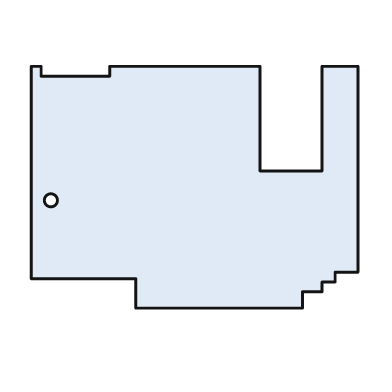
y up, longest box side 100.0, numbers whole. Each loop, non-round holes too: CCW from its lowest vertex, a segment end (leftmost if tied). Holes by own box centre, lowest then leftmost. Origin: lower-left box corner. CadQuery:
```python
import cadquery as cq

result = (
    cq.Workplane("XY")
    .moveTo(32.0, 0.0)
    .lineTo(83.0, 0.0)
    .lineTo(83.0, 5.0)
    .lineTo(89.0, 5.0)
    .lineTo(89.0, 8.0)
    .lineTo(93.0, 8.0)
    .lineTo(93.0, 11.0)
    .lineTo(100.0, 11.0)
    .lineTo(100.0, 74.0)
    .lineTo(89.0, 74.0)
    .lineTo(89.0, 42.0)
    .lineTo(70.0, 42.0)
    .lineTo(70.0, 74.0)
    .lineTo(24.0, 74.0)
    .lineTo(24.0, 71.0)
    .lineTo(3.0, 71.0)
    .lineTo(3.0, 74.0)
    .lineTo(0.0, 74.0)
    .lineTo(0.0, 9.0)
    .lineTo(32.0, 9.0)
    .close()
    .moveTo(6.0, 33.0)
    .circle(2.0)
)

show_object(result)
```